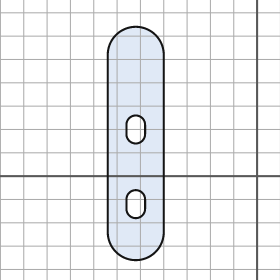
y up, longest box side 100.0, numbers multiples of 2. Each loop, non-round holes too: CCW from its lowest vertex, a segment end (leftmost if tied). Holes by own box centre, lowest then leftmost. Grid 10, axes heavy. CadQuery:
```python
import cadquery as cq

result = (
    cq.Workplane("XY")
    .moveTo(-64.0, -24.0)
    .threePointArc((-52.0, -36.0), (-40.0, -24.0))
    .lineTo(-40.0, 52.0)
    .threePointArc((-52.0, 64.0), (-64.0, 52.0))
    .close()
    .moveTo(-56.0, -14.0)
    .threePointArc((-52.0, -18.0), (-48.0, -14.0))
    .lineTo(-48.0, -10.0)
    .threePointArc((-52.0, -6.0), (-56.0, -10.0))
    .close()
    .moveTo(-56.0, 18.0)
    .threePointArc((-52.0, 14.0), (-48.0, 18.0))
    .lineTo(-48.0, 22.0)
    .threePointArc((-52.0, 26.0), (-56.0, 22.0))
    .close()
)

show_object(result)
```